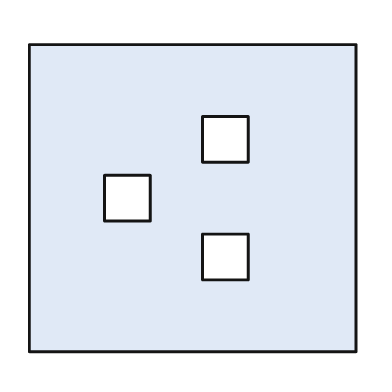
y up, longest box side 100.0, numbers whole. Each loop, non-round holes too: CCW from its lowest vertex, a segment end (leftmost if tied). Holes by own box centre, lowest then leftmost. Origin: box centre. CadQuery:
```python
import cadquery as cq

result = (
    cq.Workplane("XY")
    .moveTo(-50.0, -47.0)
    .lineTo(50.0, -47.0)
    .lineTo(50.0, 47.0)
    .lineTo(-50.0, 47.0)
    .close()
    .moveTo(3.0, -25.0)
    .lineTo(17.0, -25.0)
    .lineTo(17.0, -11.0)
    .lineTo(3.0, -11.0)
    .close()
    .moveTo(-27.0, -7.0)
    .lineTo(-13.0, -7.0)
    .lineTo(-13.0, 7.0)
    .lineTo(-27.0, 7.0)
    .close()
    .moveTo(3.0, 11.0)
    .lineTo(17.0, 11.0)
    .lineTo(17.0, 25.0)
    .lineTo(3.0, 25.0)
    .close()
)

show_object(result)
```